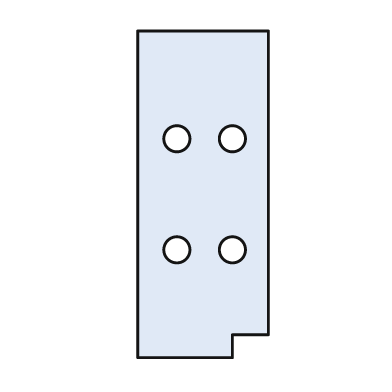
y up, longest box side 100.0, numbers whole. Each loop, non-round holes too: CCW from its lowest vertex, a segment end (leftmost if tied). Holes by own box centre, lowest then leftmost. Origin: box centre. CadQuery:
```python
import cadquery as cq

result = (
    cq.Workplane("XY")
    .moveTo(-20.0, -50.0)
    .lineTo(9.0, -50.0)
    .lineTo(9.0, -43.0)
    .lineTo(20.0, -43.0)
    .lineTo(20.0, 50.0)
    .lineTo(-20.0, 50.0)
    .close()
    .moveTo(-8.0, -17.0)
    .circle(4.0)
    .moveTo(9.0, -17.0)
    .circle(4.0)
    .moveTo(-8.0, 17.0)
    .circle(4.0)
    .moveTo(9.0, 17.0)
    .circle(4.0)
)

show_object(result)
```